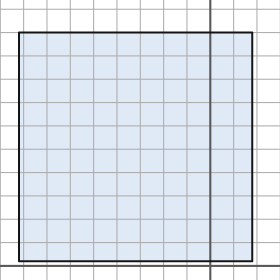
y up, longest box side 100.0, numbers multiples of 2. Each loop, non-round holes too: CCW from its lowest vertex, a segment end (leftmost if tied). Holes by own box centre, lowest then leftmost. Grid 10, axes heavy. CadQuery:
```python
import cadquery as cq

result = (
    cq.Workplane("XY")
    .moveTo(-82.0, 2.0)
    .lineTo(18.0, 2.0)
    .lineTo(18.0, 100.0)
    .lineTo(-82.0, 100.0)
    .close()
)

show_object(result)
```